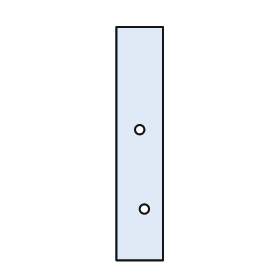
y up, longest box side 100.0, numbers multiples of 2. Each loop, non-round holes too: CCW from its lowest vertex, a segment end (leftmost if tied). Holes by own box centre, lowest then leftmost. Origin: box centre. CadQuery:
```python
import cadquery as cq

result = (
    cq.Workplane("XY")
    .moveTo(-10.0, -50.0)
    .lineTo(10.0, -50.0)
    .lineTo(10.0, 50.0)
    .lineTo(-10.0, 50.0)
    .close()
    .moveTo(2.0, -28.0)
    .circle(2.0)
    .moveTo(0.0, 6.0)
    .circle(2.0)
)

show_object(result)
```